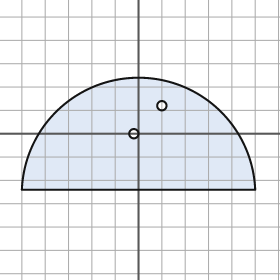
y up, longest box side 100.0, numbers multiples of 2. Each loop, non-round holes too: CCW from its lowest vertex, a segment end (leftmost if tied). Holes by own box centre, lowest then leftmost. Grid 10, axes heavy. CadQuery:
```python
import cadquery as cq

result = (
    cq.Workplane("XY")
    .moveTo(-50.0, -24.0)
    .lineTo(50.0, -24.0)
    .threePointArc((0.0, 24.0), (-50.0, -24.0))
    .close()
    .moveTo(-2.0, 0.0)
    .circle(2.0)
    .moveTo(10.0, 12.0)
    .circle(2.0)
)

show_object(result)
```